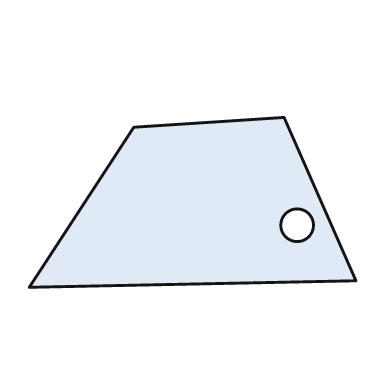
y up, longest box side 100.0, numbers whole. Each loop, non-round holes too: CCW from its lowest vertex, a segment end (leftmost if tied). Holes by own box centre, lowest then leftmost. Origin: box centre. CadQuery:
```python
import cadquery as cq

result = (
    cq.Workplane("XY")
    .moveTo(-50.0, -26.0)
    .lineTo(50.0, -24.0)
    .lineTo(28.0, 26.0)
    .lineTo(-18.0, 23.0)
    .close()
    .moveTo(32.0, -7.0)
    .circle(5.0)
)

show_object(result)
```